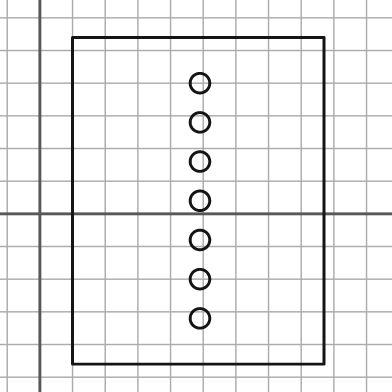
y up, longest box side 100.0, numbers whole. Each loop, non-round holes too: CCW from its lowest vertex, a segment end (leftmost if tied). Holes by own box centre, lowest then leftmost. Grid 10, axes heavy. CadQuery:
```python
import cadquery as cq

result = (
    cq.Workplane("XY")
    .moveTo(10.0, -46.0)
    .lineTo(87.0, -46.0)
    .lineTo(87.0, 54.0)
    .lineTo(10.0, 54.0)
    .close()
    .moveTo(49.0, -32.0)
    .circle(3.0)
    .moveTo(49.0, -20.0)
    .circle(3.0)
    .moveTo(49.0, -8.0)
    .circle(3.0)
    .moveTo(49.0, 4.0)
    .circle(3.0)
    .moveTo(49.0, 16.0)
    .circle(3.0)
    .moveTo(49.0, 28.0)
    .circle(3.0)
    .moveTo(49.0, 40.0)
    .circle(3.0)
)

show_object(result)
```